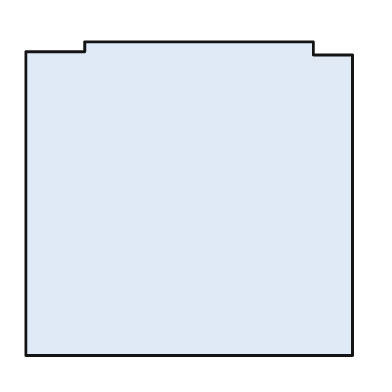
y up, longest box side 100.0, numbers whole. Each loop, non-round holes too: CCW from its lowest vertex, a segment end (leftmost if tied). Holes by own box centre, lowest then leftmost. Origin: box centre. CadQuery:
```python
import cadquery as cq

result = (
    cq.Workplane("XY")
    .moveTo(-50.0, -48.0)
    .lineTo(50.0, -48.0)
    .lineTo(50.0, 44.0)
    .lineTo(38.0, 44.0)
    .lineTo(38.0, 48.0)
    .lineTo(-32.0, 48.0)
    .lineTo(-32.0, 45.0)
    .lineTo(-50.0, 45.0)
    .close()
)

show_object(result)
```